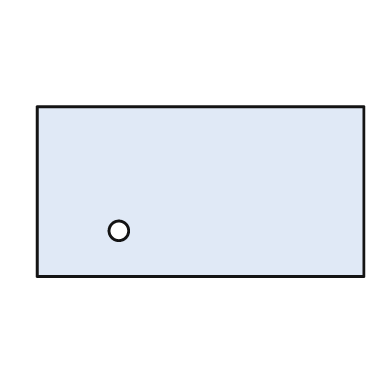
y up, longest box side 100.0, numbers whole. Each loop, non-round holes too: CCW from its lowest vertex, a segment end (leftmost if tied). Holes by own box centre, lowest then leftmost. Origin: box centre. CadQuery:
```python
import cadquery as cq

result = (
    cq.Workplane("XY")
    .moveTo(-50.0, -26.0)
    .lineTo(50.0, -26.0)
    .lineTo(50.0, 26.0)
    .lineTo(-50.0, 26.0)
    .close()
    .moveTo(-25.0, -12.0)
    .circle(3.0)
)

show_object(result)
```